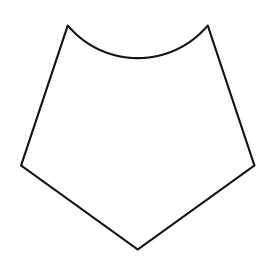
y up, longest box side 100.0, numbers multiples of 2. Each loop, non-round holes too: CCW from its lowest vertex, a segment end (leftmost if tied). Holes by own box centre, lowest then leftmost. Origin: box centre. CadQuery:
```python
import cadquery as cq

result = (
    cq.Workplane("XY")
    .moveTo(0.0, -48.0)
    .lineTo(50.0, -12.0)
    .lineTo(30.0, 48.0)
    .threePointArc((0.0, 34.0), (-30.0, 48.0))
    .lineTo(-50.0, -12.0)
    .close()
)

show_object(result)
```